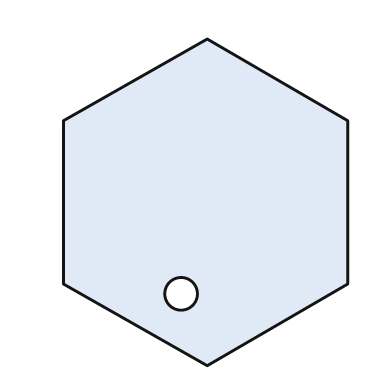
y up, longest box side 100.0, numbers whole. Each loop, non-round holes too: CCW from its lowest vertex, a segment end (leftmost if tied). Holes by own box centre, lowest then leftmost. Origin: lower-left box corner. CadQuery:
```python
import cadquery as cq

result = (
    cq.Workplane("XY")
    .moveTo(44.0, 0.0)
    .lineTo(87.0, 25.0)
    .lineTo(87.0, 75.0)
    .lineTo(44.0, 100.0)
    .lineTo(0.0, 75.0)
    .lineTo(0.0, 25.0)
    .close()
    .moveTo(36.0, 22.0)
    .circle(5.0)
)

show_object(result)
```